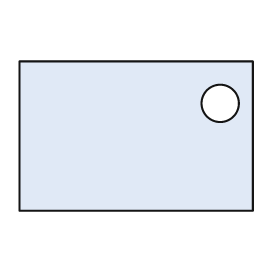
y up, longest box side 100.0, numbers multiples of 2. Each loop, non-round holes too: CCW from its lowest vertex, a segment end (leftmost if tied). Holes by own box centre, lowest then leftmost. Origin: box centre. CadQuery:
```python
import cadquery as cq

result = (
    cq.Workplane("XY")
    .moveTo(-50.0, -32.0)
    .lineTo(50.0, -32.0)
    .lineTo(50.0, 32.0)
    .lineTo(-50.0, 32.0)
    .close()
    .moveTo(36.0, 14.0)
    .circle(8.0)
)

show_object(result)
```